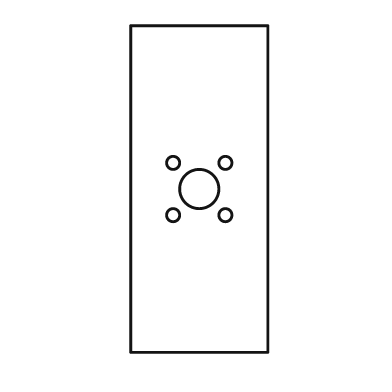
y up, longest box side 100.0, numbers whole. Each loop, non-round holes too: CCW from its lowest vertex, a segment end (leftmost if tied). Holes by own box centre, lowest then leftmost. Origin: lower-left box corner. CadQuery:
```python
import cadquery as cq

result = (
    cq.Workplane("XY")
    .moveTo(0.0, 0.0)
    .lineTo(42.0, 0.0)
    .lineTo(42.0, 100.0)
    .lineTo(0.0, 100.0)
    .close()
    .moveTo(13.0, 42.0)
    .circle(2.0)
    .moveTo(29.0, 42.0)
    .circle(2.0)
    .moveTo(21.0, 50.0)
    .circle(6.0)
    .moveTo(13.0, 58.0)
    .circle(2.0)
    .moveTo(29.0, 58.0)
    .circle(2.0)
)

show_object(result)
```